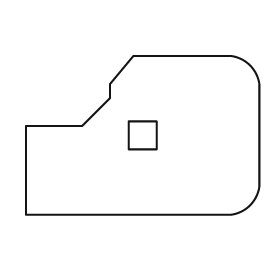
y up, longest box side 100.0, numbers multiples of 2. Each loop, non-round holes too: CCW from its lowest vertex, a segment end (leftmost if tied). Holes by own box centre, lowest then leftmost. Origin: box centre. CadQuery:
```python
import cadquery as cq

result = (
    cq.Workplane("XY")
    .moveTo(-50.0, -34.0)
    .lineTo(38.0, -34.0)
    .threePointArc((46.0, -30.0), (50.0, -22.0))
    .lineTo(50.0, 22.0)
    .threePointArc((46.0, 30.0), (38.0, 34.0))
    .lineTo(-4.0, 34.0)
    .lineTo(-14.0, 22.0)
    .lineTo(-14.0, 16.0)
    .lineTo(-26.0, 4.0)
    .lineTo(-50.0, 4.0)
    .close()
    .moveTo(-6.0, -6.0)
    .lineTo(6.0, -6.0)
    .lineTo(6.0, 6.0)
    .lineTo(-6.0, 6.0)
    .close()
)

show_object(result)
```